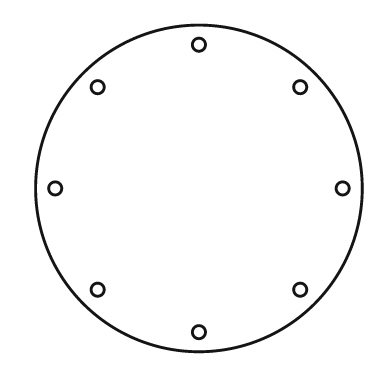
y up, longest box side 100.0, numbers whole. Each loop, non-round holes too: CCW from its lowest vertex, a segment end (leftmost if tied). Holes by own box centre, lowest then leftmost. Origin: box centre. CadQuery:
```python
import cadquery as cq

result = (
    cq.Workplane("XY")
    .moveTo(0.0, 0.0)
    .circle(50.0)
    .moveTo(0.0, -44.0)
    .circle(2.0)
    .moveTo(-31.0, -31.0)
    .circle(2.0)
    .moveTo(31.0, -31.0)
    .circle(2.0)
    .moveTo(-44.0, 0.0)
    .circle(2.0)
    .moveTo(44.0, 0.0)
    .circle(2.0)
    .moveTo(-31.0, 31.0)
    .circle(2.0)
    .moveTo(31.0, 31.0)
    .circle(2.0)
    .moveTo(0.0, 44.0)
    .circle(2.0)
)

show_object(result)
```